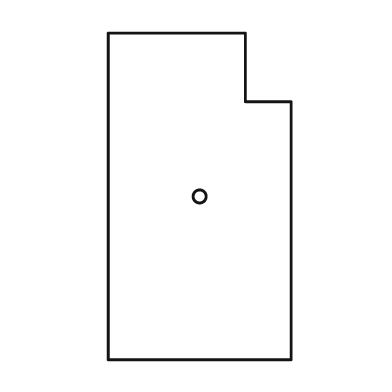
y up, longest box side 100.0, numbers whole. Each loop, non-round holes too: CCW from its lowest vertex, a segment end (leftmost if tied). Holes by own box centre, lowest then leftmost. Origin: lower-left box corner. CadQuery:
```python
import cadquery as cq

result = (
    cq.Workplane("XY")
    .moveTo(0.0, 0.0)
    .lineTo(56.0, 0.0)
    .lineTo(56.0, 79.0)
    .lineTo(42.0, 79.0)
    .lineTo(42.0, 100.0)
    .lineTo(0.0, 100.0)
    .close()
    .moveTo(28.0, 50.0)
    .circle(2.0)
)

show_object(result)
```